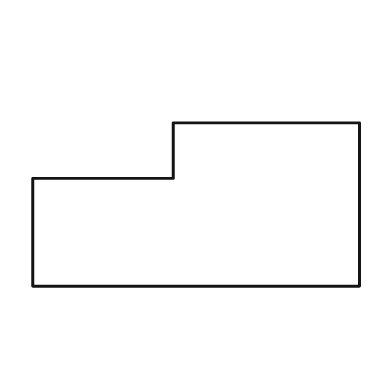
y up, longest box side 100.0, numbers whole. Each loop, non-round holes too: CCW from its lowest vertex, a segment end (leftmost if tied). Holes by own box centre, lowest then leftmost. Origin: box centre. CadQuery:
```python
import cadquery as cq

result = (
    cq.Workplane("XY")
    .moveTo(-50.0, -25.0)
    .lineTo(50.0, -25.0)
    .lineTo(50.0, 25.0)
    .lineTo(-7.0, 25.0)
    .lineTo(-7.0, 8.0)
    .lineTo(-50.0, 8.0)
    .close()
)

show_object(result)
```